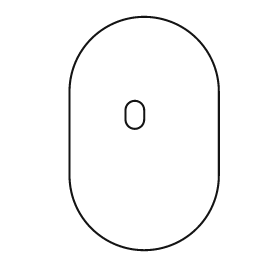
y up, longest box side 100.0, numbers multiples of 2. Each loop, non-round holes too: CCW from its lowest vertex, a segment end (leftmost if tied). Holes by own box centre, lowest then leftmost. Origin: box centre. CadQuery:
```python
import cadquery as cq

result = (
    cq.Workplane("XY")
    .moveTo(-32.0, -18.0)
    .threePointArc((0.0, -50.0), (32.0, -18.0))
    .lineTo(32.0, 18.0)
    .threePointArc((0.0, 50.0), (-32.0, 18.0))
    .close()
    .moveTo(-8.0, 6.0)
    .threePointArc((-4.0, 2.0), (0.0, 6.0))
    .lineTo(0.0, 10.0)
    .threePointArc((-4.0, 14.0), (-8.0, 10.0))
    .close()
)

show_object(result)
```